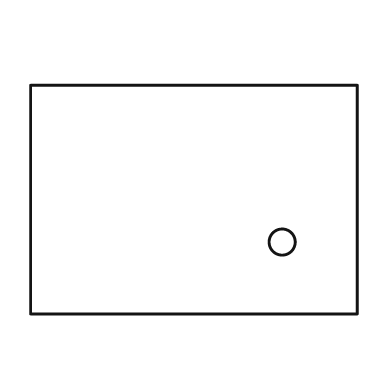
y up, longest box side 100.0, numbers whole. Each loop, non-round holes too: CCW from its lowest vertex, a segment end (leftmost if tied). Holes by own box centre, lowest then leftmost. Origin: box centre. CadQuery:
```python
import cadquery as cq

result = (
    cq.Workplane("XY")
    .moveTo(-50.0, -35.0)
    .lineTo(50.0, -35.0)
    .lineTo(50.0, 35.0)
    .lineTo(-50.0, 35.0)
    .close()
    .moveTo(27.0, -13.0)
    .circle(4.0)
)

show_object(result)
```